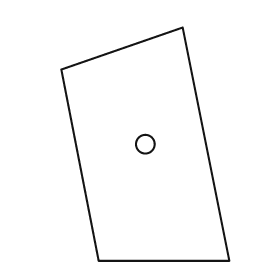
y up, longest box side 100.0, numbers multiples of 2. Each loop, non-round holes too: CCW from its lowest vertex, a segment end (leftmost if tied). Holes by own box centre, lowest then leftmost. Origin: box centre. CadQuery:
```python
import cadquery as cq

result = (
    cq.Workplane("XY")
    .moveTo(-20.0, -50.0)
    .lineTo(36.0, -50.0)
    .lineTo(16.0, 50.0)
    .lineTo(-36.0, 32.0)
    .close()
    .moveTo(0.0, 0.0)
    .circle(4.0)
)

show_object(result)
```